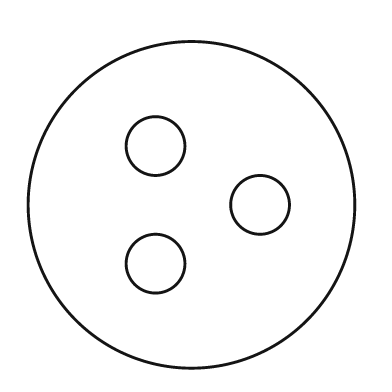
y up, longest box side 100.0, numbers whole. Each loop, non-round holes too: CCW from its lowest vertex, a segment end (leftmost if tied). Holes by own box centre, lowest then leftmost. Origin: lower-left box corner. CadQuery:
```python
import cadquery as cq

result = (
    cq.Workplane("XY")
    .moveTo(50.0, 50.0)
    .circle(50.0)
    .moveTo(39.0, 32.0)
    .circle(9.0)
    .moveTo(71.0, 50.0)
    .circle(9.0)
    .moveTo(39.0, 68.0)
    .circle(9.0)
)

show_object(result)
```